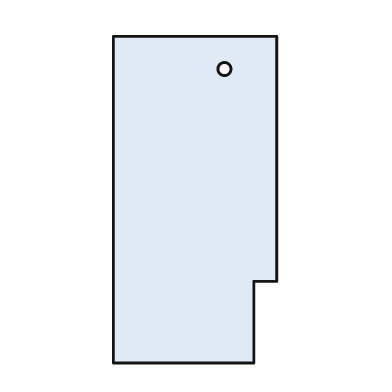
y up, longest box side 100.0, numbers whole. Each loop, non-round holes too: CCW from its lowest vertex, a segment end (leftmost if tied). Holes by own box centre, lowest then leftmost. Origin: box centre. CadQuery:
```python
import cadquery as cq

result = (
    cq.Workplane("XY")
    .moveTo(-25.0, -50.0)
    .lineTo(18.0, -50.0)
    .lineTo(18.0, -25.0)
    .lineTo(25.0, -25.0)
    .lineTo(25.0, 50.0)
    .lineTo(-25.0, 50.0)
    .close()
    .moveTo(9.0, 40.0)
    .circle(2.0)
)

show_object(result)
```